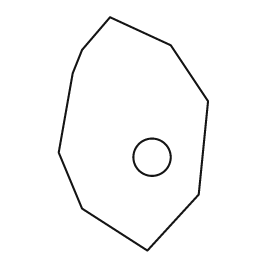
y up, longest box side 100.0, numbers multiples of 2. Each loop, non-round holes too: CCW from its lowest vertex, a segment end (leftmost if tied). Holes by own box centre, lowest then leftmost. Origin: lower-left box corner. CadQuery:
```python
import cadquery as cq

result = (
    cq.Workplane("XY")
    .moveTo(38.0, 0.0)
    .lineTo(60.0, 24.0)
    .lineTo(64.0, 64.0)
    .lineTo(48.0, 88.0)
    .lineTo(22.0, 100.0)
    .lineTo(10.0, 86.0)
    .lineTo(6.0, 76.0)
    .lineTo(0.0, 42.0)
    .lineTo(10.0, 18.0)
    .close()
    .moveTo(40.0, 40.0)
    .circle(8.0)
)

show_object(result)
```